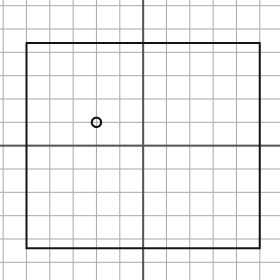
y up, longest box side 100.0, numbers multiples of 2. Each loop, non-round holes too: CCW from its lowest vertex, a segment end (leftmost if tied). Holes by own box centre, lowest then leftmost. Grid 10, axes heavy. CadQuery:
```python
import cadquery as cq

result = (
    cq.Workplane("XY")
    .moveTo(-50.0, -44.0)
    .lineTo(50.0, -44.0)
    .lineTo(50.0, 44.0)
    .lineTo(-50.0, 44.0)
    .close()
    .moveTo(-20.0, 10.0)
    .circle(2.0)
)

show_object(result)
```